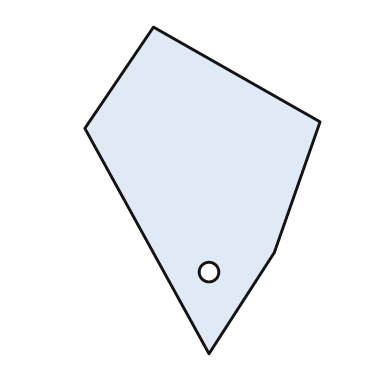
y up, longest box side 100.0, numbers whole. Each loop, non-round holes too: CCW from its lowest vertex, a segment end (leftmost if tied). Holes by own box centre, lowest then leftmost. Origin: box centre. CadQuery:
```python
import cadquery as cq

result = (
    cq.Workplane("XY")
    .moveTo(2.0, -50.0)
    .lineTo(22.0, -19.0)
    .lineTo(36.0, 21.0)
    .lineTo(-15.0, 50.0)
    .lineTo(-36.0, 19.0)
    .close()
    .moveTo(2.0, -25.0)
    .circle(3.0)
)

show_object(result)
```